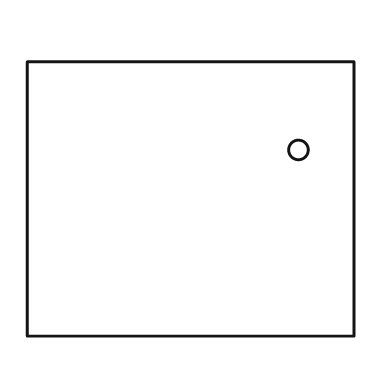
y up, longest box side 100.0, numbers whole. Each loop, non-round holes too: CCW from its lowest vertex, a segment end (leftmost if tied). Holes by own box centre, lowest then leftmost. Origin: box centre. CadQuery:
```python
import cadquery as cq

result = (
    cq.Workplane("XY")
    .moveTo(-50.0, -42.0)
    .lineTo(50.0, -42.0)
    .lineTo(50.0, 42.0)
    .lineTo(-50.0, 42.0)
    .close()
    .moveTo(33.0, 15.0)
    .circle(3.0)
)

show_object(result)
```